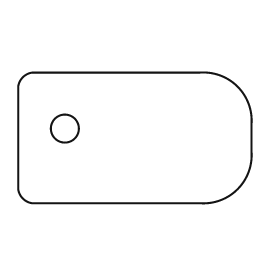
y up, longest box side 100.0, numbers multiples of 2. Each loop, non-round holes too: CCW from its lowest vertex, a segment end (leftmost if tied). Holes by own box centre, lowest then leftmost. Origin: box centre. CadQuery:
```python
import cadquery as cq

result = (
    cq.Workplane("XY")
    .moveTo(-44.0, -28.0)
    .lineTo(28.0, -28.0)
    .threePointArc((44.0, -22.0), (50.0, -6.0))
    .lineTo(50.0, 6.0)
    .threePointArc((44.0, 22.0), (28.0, 28.0))
    .lineTo(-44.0, 28.0)
    .threePointArc((-48.0, 26.0), (-50.0, 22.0))
    .lineTo(-50.0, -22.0)
    .threePointArc((-48.0, -26.0), (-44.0, -28.0))
    .close()
    .moveTo(-30.0, 4.0)
    .circle(6.0)
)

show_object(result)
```